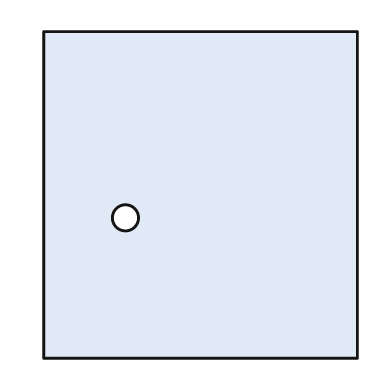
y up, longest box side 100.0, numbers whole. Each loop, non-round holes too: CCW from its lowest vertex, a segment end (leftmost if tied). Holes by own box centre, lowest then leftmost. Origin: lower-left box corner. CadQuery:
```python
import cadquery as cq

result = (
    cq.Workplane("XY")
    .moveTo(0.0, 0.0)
    .lineTo(96.0, 0.0)
    .lineTo(96.0, 100.0)
    .lineTo(0.0, 100.0)
    .close()
    .moveTo(25.0, 43.0)
    .circle(4.0)
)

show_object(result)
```